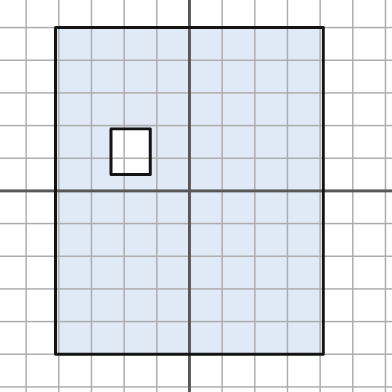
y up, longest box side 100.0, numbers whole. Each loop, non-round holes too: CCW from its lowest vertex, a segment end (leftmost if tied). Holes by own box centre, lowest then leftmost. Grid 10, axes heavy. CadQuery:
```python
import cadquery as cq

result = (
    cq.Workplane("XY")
    .moveTo(-41.0, -50.0)
    .lineTo(41.0, -50.0)
    .lineTo(41.0, 50.0)
    .lineTo(-41.0, 50.0)
    .close()
    .moveTo(-24.0, 5.0)
    .lineTo(-12.0, 5.0)
    .lineTo(-12.0, 19.0)
    .lineTo(-24.0, 19.0)
    .close()
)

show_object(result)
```